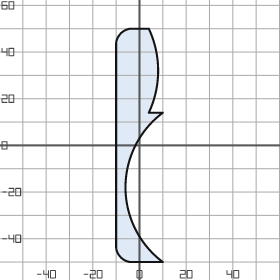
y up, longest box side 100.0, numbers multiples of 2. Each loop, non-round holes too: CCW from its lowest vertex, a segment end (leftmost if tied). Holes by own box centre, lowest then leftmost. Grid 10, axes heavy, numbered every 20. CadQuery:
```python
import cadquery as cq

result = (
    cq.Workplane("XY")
    .moveTo(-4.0, -50.0)
    .lineTo(10.0, -50.0)
    .threePointArc((-6.0, -18.0), (10.0, 14.0))
    .lineTo(4.0, 14.0)
    .threePointArc((8.0, 32.0), (4.0, 50.0))
    .lineTo(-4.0, 50.0)
    .threePointArc((-8.0, 48.0), (-10.0, 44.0))
    .lineTo(-10.0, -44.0)
    .threePointArc((-8.0, -48.0), (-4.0, -50.0))
    .close()
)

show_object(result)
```